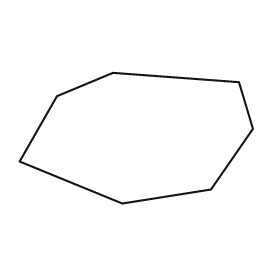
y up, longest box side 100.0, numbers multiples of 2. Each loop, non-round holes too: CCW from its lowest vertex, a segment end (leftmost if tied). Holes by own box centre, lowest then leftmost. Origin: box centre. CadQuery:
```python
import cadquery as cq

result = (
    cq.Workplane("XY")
    .moveTo(-6.0, -28.0)
    .lineTo(32.0, -22.0)
    .lineTo(50.0, 4.0)
    .lineTo(44.0, 24.0)
    .lineTo(-10.0, 28.0)
    .lineTo(-34.0, 18.0)
    .lineTo(-50.0, -10.0)
    .close()
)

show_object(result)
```